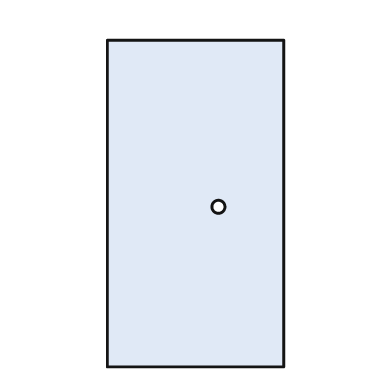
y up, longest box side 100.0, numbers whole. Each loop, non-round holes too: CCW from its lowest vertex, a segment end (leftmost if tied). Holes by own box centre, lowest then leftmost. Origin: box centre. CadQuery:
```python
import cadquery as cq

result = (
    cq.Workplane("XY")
    .moveTo(-27.0, -50.0)
    .lineTo(27.0, -50.0)
    .lineTo(27.0, 50.0)
    .lineTo(-27.0, 50.0)
    .close()
    .moveTo(7.0, -1.0)
    .circle(2.0)
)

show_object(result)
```